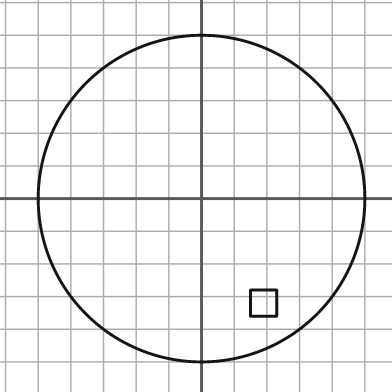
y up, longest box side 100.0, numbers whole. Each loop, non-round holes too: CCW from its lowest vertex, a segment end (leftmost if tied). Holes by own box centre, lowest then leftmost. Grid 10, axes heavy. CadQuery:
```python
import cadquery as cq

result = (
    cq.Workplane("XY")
    .moveTo(0.0, 0.0)
    .circle(50.0)
    .moveTo(15.0, -36.0)
    .lineTo(23.0, -36.0)
    .lineTo(23.0, -28.0)
    .lineTo(15.0, -28.0)
    .close()
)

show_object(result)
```